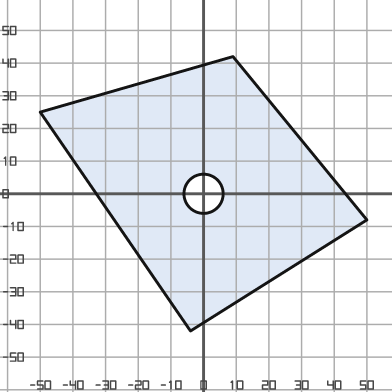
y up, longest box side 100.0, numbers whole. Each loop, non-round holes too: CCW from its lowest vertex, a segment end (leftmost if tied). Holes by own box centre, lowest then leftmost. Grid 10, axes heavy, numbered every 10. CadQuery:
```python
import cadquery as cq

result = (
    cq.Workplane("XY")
    .moveTo(-4.0, -42.0)
    .lineTo(50.0, -8.0)
    .lineTo(9.0, 42.0)
    .lineTo(-50.0, 25.0)
    .close()
    .moveTo(0.0, 0.0)
    .circle(6.0)
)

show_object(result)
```